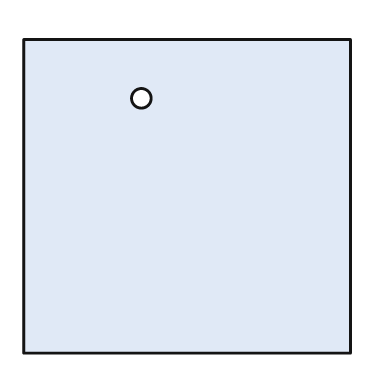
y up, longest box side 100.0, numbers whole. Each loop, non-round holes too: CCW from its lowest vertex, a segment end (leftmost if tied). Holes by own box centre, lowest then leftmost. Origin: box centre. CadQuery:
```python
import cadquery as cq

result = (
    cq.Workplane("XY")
    .moveTo(-50.0, -48.0)
    .lineTo(50.0, -48.0)
    .lineTo(50.0, 48.0)
    .lineTo(-50.0, 48.0)
    .close()
    .moveTo(-14.0, 30.0)
    .circle(3.0)
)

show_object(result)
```